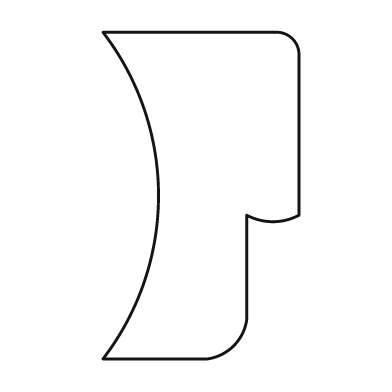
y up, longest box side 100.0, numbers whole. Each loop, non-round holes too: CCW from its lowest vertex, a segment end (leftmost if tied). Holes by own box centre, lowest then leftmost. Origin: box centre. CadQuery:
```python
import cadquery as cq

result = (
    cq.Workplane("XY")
    .moveTo(-30.0, -50.0)
    .lineTo(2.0, -50.0)
    .threePointArc((10.0, -46.0), (14.0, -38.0))
    .lineTo(14.0, -6.0)
    .threePointArc((22.0, -8.0), (30.0, -6.0))
    .lineTo(30.0, 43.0)
    .threePointArc((28.0, 48.0), (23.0, 50.0))
    .lineTo(-30.0, 50.0)
    .threePointArc((-13.0, 0.0), (-30.0, -50.0))
    .close()
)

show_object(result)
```